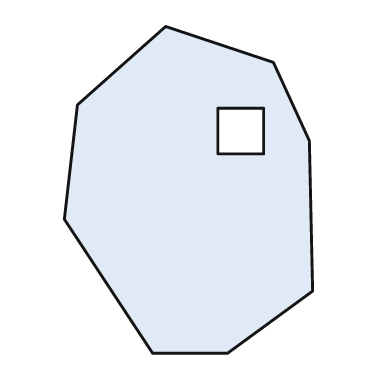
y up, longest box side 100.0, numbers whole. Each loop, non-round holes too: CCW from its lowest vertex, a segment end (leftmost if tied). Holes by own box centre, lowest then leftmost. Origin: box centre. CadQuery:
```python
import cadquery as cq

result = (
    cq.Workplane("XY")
    .moveTo(-11.0, -50.0)
    .lineTo(12.0, -50.0)
    .lineTo(38.0, -31.0)
    .lineTo(37.0, 15.0)
    .lineTo(26.0, 39.0)
    .lineTo(-7.0, 50.0)
    .lineTo(-34.0, 26.0)
    .lineTo(-38.0, -9.0)
    .close()
    .moveTo(9.0, 11.0)
    .lineTo(23.0, 11.0)
    .lineTo(23.0, 25.0)
    .lineTo(9.0, 25.0)
    .close()
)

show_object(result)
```